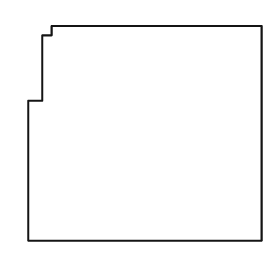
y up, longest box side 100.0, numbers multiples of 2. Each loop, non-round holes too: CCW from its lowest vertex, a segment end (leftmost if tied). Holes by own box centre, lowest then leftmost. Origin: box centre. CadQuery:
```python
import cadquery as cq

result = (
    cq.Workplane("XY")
    .moveTo(-50.0, -46.0)
    .lineTo(50.0, -46.0)
    .lineTo(50.0, 46.0)
    .lineTo(-40.0, 46.0)
    .lineTo(-40.0, 42.0)
    .lineTo(-44.0, 42.0)
    .lineTo(-44.0, 14.0)
    .lineTo(-50.0, 14.0)
    .close()
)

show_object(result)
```